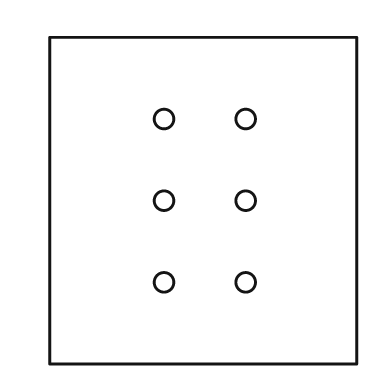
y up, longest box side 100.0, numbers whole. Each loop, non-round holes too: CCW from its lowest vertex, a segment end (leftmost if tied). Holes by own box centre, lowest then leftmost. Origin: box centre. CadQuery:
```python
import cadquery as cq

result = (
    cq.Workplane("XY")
    .moveTo(-47.0, -50.0)
    .lineTo(47.0, -50.0)
    .lineTo(47.0, 50.0)
    .lineTo(-47.0, 50.0)
    .close()
    .moveTo(-12.0, -25.0)
    .circle(3.0)
    .moveTo(13.0, -25.0)
    .circle(3.0)
    .moveTo(-12.0, 0.0)
    .circle(3.0)
    .moveTo(13.0, 0.0)
    .circle(3.0)
    .moveTo(-12.0, 25.0)
    .circle(3.0)
    .moveTo(13.0, 25.0)
    .circle(3.0)
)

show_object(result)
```